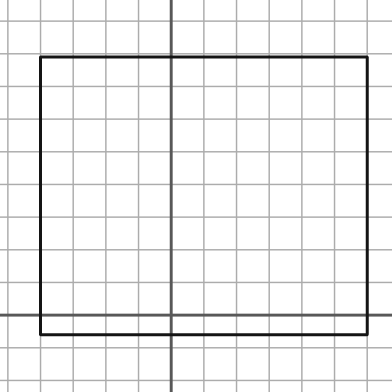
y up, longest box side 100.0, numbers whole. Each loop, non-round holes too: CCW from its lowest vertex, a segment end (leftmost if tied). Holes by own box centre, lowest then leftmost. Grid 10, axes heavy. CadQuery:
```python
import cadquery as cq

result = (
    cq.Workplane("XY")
    .moveTo(-40.0, -6.0)
    .lineTo(60.0, -6.0)
    .lineTo(60.0, 79.0)
    .lineTo(-40.0, 79.0)
    .close()
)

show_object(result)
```